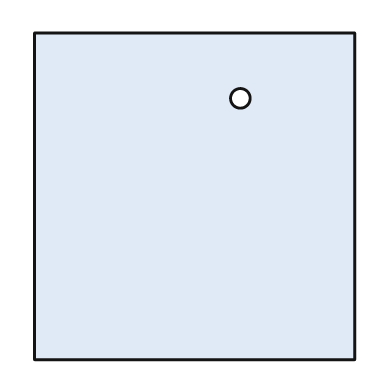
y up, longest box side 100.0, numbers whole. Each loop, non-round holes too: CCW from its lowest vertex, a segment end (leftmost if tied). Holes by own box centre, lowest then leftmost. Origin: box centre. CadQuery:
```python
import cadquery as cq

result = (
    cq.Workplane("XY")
    .moveTo(-49.0, -50.0)
    .lineTo(49.0, -50.0)
    .lineTo(49.0, 50.0)
    .lineTo(-49.0, 50.0)
    .close()
    .moveTo(14.0, 30.0)
    .circle(3.0)
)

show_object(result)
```